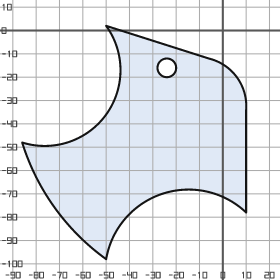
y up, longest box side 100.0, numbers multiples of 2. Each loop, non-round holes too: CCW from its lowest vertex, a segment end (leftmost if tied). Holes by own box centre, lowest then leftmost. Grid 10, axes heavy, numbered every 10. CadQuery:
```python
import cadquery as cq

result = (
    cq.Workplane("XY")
    .moveTo(-50.0, -98.0)
    .threePointArc((-26.0, -70.0), (10.0, -78.0))
    .lineTo(10.0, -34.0)
    .threePointArc((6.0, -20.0), (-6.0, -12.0))
    .lineTo(-50.0, 2.0)
    .threePointArc((-50.0, -36.0), (-86.0, -48.0))
    .threePointArc((-72.0, -76.0), (-50.0, -98.0))
    .close()
    .moveTo(-24.0, -16.0)
    .circle(4.0)
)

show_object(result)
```